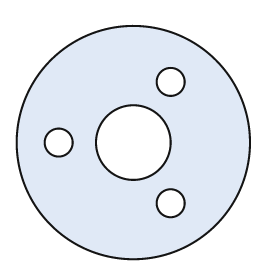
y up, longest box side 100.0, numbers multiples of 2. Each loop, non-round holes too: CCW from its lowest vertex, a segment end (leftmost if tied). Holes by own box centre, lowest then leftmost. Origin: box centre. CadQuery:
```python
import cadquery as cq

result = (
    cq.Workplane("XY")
    .moveTo(0.0, 0.0)
    .circle(50.0)
    .moveTo(16.0, -26.0)
    .circle(6.0)
    .moveTo(-32.0, 0.0)
    .circle(6.0)
    .moveTo(0.0, 0.0)
    .circle(16.0)
    .moveTo(16.0, 26.0)
    .circle(6.0)
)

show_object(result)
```